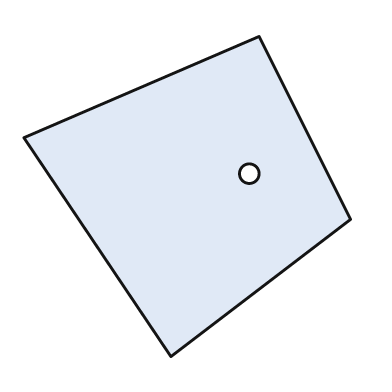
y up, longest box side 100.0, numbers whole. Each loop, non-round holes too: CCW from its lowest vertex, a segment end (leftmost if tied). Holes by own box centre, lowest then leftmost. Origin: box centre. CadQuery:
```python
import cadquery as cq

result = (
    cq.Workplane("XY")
    .moveTo(-5.0, -49.0)
    .lineTo(50.0, -7.0)
    .lineTo(22.0, 49.0)
    .lineTo(-50.0, 18.0)
    .close()
    .moveTo(19.0, 7.0)
    .circle(3.0)
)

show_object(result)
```